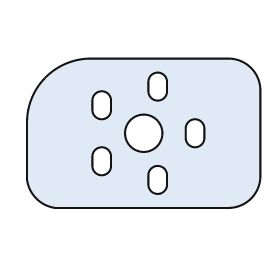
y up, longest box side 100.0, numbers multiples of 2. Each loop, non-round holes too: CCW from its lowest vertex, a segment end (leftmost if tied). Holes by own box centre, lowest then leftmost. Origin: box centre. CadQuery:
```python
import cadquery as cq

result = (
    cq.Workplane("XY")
    .moveTo(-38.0, -32.0)
    .lineTo(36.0, -32.0)
    .threePointArc((46.0, -28.0), (50.0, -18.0))
    .lineTo(50.0, 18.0)
    .threePointArc((46.0, 28.0), (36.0, 32.0))
    .lineTo(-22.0, 32.0)
    .threePointArc((-42.0, 24.0), (-50.0, 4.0))
    .lineTo(-50.0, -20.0)
    .threePointArc((-46.0, -28.0), (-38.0, -32.0))
    .close()
    .moveTo(2.0, -22.0)
    .threePointArc((6.0, -26.0), (10.0, -22.0))
    .lineTo(10.0, -18.0)
    .threePointArc((6.0, -14.0), (2.0, -18.0))
    .close()
    .moveTo(-22.0, -14.0)
    .threePointArc((-18.0, -18.0), (-14.0, -14.0))
    .lineTo(-14.0, -10.0)
    .threePointArc((-18.0, -6.0), (-22.0, -10.0))
    .close()
    .moveTo(0.0, 0.0)
    .circle(8.0)
    .moveTo(18.0, -2.0)
    .threePointArc((22.0, -6.0), (26.0, -2.0))
    .lineTo(26.0, 2.0)
    .threePointArc((22.0, 6.0), (18.0, 2.0))
    .close()
    .moveTo(-22.0, 10.0)
    .threePointArc((-18.0, 6.0), (-14.0, 10.0))
    .lineTo(-14.0, 14.0)
    .threePointArc((-18.0, 18.0), (-22.0, 14.0))
    .close()
    .moveTo(2.0, 18.0)
    .threePointArc((6.0, 14.0), (10.0, 18.0))
    .lineTo(10.0, 22.0)
    .threePointArc((6.0, 26.0), (2.0, 22.0))
    .close()
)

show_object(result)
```